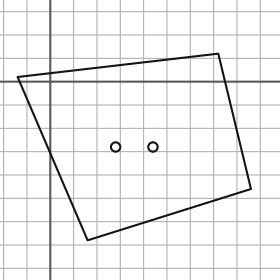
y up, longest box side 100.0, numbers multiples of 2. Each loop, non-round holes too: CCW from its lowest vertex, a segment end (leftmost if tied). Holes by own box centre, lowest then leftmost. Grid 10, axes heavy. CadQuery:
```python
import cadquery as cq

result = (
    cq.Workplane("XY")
    .moveTo(16.0, -68.0)
    .lineTo(86.0, -46.0)
    .lineTo(72.0, 12.0)
    .lineTo(-14.0, 2.0)
    .close()
    .moveTo(28.0, -28.0)
    .circle(2.0)
    .moveTo(44.0, -28.0)
    .circle(2.0)
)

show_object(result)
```